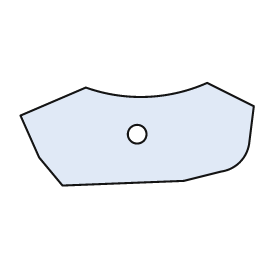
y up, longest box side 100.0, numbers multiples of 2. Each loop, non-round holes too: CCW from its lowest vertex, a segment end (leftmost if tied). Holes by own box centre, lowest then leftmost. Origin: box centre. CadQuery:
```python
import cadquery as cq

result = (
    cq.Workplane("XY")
    .moveTo(-32.0, -22.0)
    .lineTo(20.0, -20.0)
    .lineTo(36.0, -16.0)
    .threePointArc((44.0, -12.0), (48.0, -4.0))
    .lineTo(50.0, 12.0)
    .lineTo(30.0, 22.0)
    .threePointArc((4.0, 16.0), (-22.0, 20.0))
    .lineTo(-50.0, 8.0)
    .lineTo(-42.0, -10.0)
    .close()
    .moveTo(0.0, 0.0)
    .circle(4.0)
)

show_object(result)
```